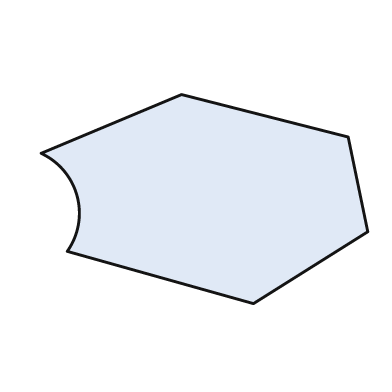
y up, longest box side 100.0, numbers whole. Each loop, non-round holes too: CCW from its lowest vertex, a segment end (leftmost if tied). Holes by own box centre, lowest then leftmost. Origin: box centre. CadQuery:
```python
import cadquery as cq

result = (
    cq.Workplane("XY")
    .moveTo(15.0, -32.0)
    .lineTo(50.0, -10.0)
    .lineTo(44.0, 19.0)
    .lineTo(-7.0, 32.0)
    .lineTo(-50.0, 14.0)
    .threePointArc((-39.0, 1.0), (-42.0, -16.0))
    .close()
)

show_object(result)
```